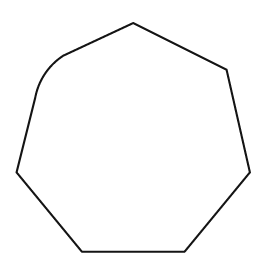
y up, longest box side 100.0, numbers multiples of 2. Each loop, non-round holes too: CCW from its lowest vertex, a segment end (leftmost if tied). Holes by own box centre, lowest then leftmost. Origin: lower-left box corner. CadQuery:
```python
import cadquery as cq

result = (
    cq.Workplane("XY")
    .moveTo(28.0, 0.0)
    .lineTo(72.0, 0.0)
    .lineTo(100.0, 34.0)
    .lineTo(90.0, 78.0)
    .lineTo(50.0, 98.0)
    .lineTo(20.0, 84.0)
    .threePointArc((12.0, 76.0), (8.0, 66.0))
    .lineTo(0.0, 34.0)
    .close()
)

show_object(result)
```